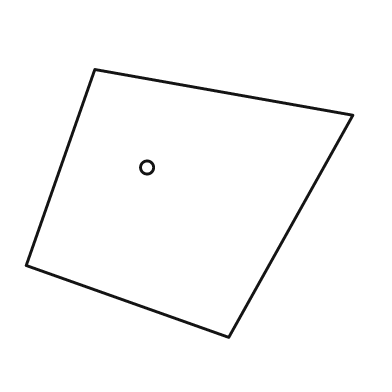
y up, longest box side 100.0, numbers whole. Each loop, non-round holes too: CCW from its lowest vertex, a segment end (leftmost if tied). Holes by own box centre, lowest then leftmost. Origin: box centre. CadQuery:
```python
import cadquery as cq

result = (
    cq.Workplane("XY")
    .moveTo(12.0, -41.0)
    .lineTo(50.0, 27.0)
    .lineTo(-29.0, 41.0)
    .lineTo(-50.0, -19.0)
    .close()
    .moveTo(-13.0, 11.0)
    .circle(2.0)
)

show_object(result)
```